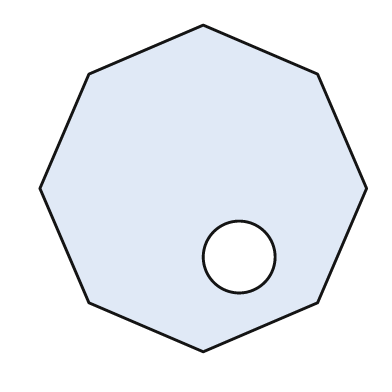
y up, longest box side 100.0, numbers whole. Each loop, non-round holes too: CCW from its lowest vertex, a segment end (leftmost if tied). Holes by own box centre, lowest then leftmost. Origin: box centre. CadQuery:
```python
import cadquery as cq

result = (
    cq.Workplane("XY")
    .moveTo(0.0, -50.0)
    .lineTo(35.0, -35.0)
    .lineTo(50.0, 0.0)
    .lineTo(35.0, 35.0)
    .lineTo(0.0, 50.0)
    .lineTo(-35.0, 35.0)
    .lineTo(-50.0, 0.0)
    .lineTo(-35.0, -35.0)
    .close()
    .moveTo(11.0, -21.0)
    .circle(11.0)
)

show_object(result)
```